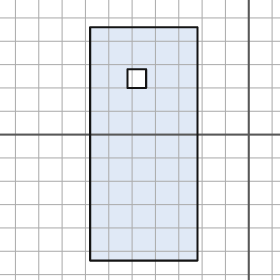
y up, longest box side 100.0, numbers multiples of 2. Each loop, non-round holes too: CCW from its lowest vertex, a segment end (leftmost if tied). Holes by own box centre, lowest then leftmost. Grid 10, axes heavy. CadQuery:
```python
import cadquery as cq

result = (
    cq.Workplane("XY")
    .moveTo(-68.0, -54.0)
    .lineTo(-22.0, -54.0)
    .lineTo(-22.0, 46.0)
    .lineTo(-68.0, 46.0)
    .close()
    .moveTo(-52.0, 20.0)
    .lineTo(-44.0, 20.0)
    .lineTo(-44.0, 28.0)
    .lineTo(-52.0, 28.0)
    .close()
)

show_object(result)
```